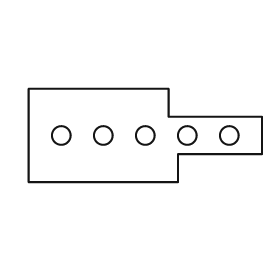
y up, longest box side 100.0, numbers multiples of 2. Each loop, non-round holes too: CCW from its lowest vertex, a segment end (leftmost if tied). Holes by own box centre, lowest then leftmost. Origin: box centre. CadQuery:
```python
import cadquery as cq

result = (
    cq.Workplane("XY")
    .moveTo(-50.0, -20.0)
    .lineTo(14.0, -20.0)
    .lineTo(14.0, -8.0)
    .lineTo(50.0, -8.0)
    .lineTo(50.0, 8.0)
    .lineTo(10.0, 8.0)
    .lineTo(10.0, 20.0)
    .lineTo(-50.0, 20.0)
    .close()
    .moveTo(-36.0, 0.0)
    .circle(4.0)
    .moveTo(-18.0, 0.0)
    .circle(4.0)
    .moveTo(0.0, 0.0)
    .circle(4.0)
    .moveTo(18.0, 0.0)
    .circle(4.0)
    .moveTo(36.0, 0.0)
    .circle(4.0)
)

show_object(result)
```